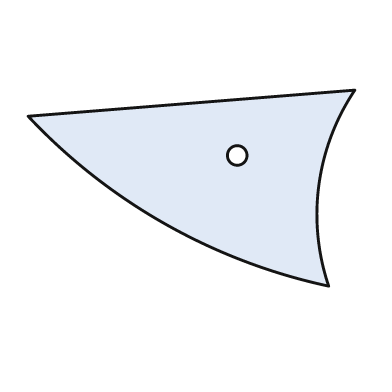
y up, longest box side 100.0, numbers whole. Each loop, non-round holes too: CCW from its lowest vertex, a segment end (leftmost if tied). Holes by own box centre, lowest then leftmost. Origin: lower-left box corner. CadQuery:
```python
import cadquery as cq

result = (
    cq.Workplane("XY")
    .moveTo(92.0, 0.0)
    .threePointArc((89.0, 31.0), (100.0, 60.0))
    .lineTo(0.0, 52.0)
    .threePointArc((42.0, 19.0), (92.0, 0.0))
    .close()
    .moveTo(64.0, 40.0)
    .circle(3.0)
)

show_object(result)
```